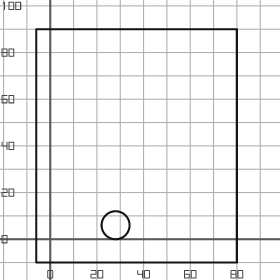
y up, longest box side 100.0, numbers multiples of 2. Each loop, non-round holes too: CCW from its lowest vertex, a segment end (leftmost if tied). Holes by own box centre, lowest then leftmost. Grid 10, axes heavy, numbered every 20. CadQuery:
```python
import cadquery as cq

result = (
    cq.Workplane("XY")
    .moveTo(-6.0, -10.0)
    .lineTo(80.0, -10.0)
    .lineTo(80.0, 90.0)
    .lineTo(-6.0, 90.0)
    .close()
    .moveTo(28.0, 6.0)
    .circle(6.0)
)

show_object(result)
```